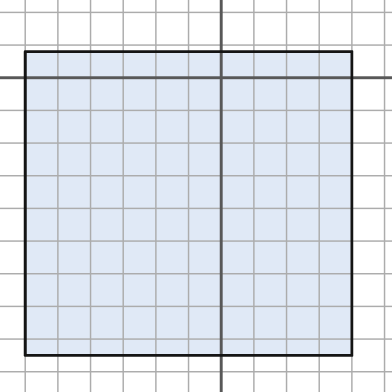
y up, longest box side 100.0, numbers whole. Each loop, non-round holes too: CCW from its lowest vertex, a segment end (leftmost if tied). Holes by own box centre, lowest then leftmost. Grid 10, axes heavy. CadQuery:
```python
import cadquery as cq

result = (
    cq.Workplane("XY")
    .moveTo(-60.0, -85.0)
    .lineTo(40.0, -85.0)
    .lineTo(40.0, 8.0)
    .lineTo(-60.0, 8.0)
    .close()
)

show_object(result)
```